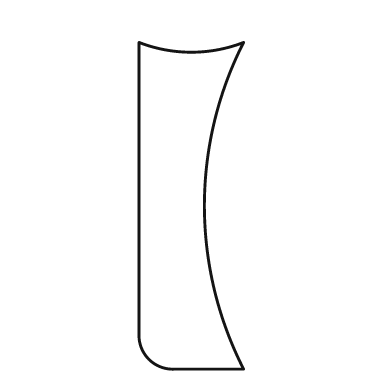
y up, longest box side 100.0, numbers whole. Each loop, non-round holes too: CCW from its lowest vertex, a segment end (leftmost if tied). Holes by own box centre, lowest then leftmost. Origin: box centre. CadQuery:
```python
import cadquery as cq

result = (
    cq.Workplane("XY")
    .moveTo(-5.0, -50.0)
    .lineTo(16.0, -50.0)
    .threePointArc((4.0, 0.0), (16.0, 50.0))
    .threePointArc((0.0, 47.0), (-16.0, 50.0))
    .lineTo(-16.0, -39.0)
    .threePointArc((-13.0, -47.0), (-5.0, -50.0))
    .close()
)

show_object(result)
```